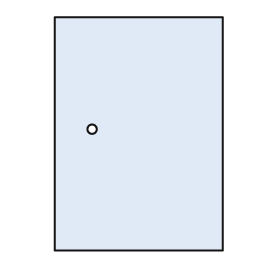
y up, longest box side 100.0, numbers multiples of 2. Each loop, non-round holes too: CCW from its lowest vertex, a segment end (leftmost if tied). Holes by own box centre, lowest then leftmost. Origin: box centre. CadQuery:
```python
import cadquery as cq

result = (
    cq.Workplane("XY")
    .moveTo(-36.0, -50.0)
    .lineTo(36.0, -50.0)
    .lineTo(36.0, 50.0)
    .lineTo(-36.0, 50.0)
    .close()
    .moveTo(-20.0, 2.0)
    .circle(2.0)
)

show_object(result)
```